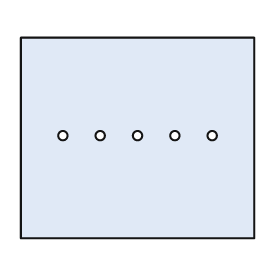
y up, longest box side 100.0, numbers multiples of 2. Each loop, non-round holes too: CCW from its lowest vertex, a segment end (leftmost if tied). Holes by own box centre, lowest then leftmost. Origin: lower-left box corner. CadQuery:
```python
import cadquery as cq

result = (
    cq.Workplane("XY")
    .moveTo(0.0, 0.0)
    .lineTo(100.0, 0.0)
    .lineTo(100.0, 86.0)
    .lineTo(0.0, 86.0)
    .close()
    .moveTo(18.0, 44.0)
    .circle(2.0)
    .moveTo(34.0, 44.0)
    .circle(2.0)
    .moveTo(50.0, 44.0)
    .circle(2.0)
    .moveTo(66.0, 44.0)
    .circle(2.0)
    .moveTo(82.0, 44.0)
    .circle(2.0)
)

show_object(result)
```